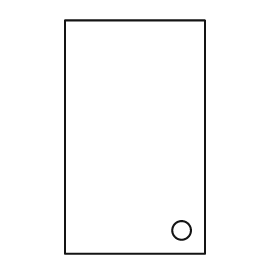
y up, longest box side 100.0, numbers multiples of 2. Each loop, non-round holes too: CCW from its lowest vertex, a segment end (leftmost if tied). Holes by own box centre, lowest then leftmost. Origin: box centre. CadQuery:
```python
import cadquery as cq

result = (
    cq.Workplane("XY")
    .moveTo(-30.0, -50.0)
    .lineTo(30.0, -50.0)
    .lineTo(30.0, 50.0)
    .lineTo(-30.0, 50.0)
    .close()
    .moveTo(20.0, -40.0)
    .circle(4.0)
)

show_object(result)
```